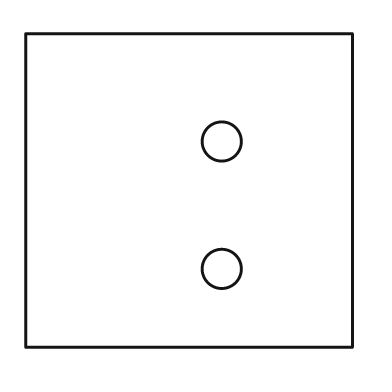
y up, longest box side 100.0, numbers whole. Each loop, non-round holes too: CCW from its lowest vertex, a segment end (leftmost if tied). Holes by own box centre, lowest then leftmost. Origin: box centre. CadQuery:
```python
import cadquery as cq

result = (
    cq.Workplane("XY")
    .moveTo(-50.0, -48.0)
    .lineTo(50.0, -48.0)
    .lineTo(50.0, 48.0)
    .lineTo(-50.0, 48.0)
    .close()
    .moveTo(10.0, -24.0)
    .circle(6.0)
    .moveTo(10.0, 15.0)
    .circle(6.0)
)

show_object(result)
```